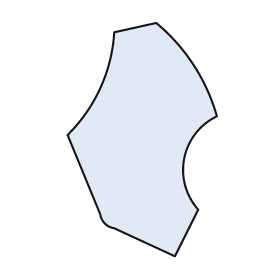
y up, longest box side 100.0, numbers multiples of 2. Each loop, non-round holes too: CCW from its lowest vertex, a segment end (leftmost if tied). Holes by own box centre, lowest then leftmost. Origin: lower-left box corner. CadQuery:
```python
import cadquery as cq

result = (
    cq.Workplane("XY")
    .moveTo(46.0, 0.0)
    .lineTo(56.0, 20.0)
    .threePointArc((50.0, 42.0), (64.0, 60.0))
    .threePointArc((54.0, 82.0), (38.0, 100.0))
    .lineTo(20.0, 96.0)
    .threePointArc((14.0, 72.0), (0.0, 52.0))
    .lineTo(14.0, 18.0)
    .threePointArc((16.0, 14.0), (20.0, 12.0))
    .close()
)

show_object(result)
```